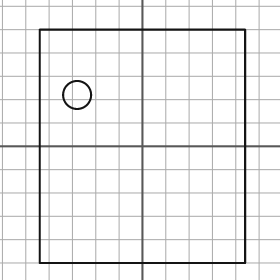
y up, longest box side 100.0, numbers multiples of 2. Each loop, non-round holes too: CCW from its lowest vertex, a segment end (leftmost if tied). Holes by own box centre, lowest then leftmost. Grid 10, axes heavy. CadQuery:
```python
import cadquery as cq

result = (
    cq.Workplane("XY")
    .moveTo(-44.0, -50.0)
    .lineTo(44.0, -50.0)
    .lineTo(44.0, 50.0)
    .lineTo(-44.0, 50.0)
    .close()
    .moveTo(-28.0, 22.0)
    .circle(6.0)
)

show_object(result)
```